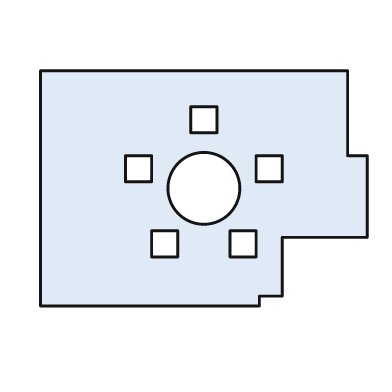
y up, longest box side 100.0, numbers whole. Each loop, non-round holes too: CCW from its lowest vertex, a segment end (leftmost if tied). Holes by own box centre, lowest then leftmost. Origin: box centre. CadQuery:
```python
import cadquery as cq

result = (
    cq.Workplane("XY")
    .moveTo(-50.0, -36.0)
    .lineTo(17.0, -36.0)
    .lineTo(17.0, -33.0)
    .lineTo(24.0, -33.0)
    .lineTo(24.0, -15.0)
    .lineTo(50.0, -15.0)
    .lineTo(50.0, 10.0)
    .lineTo(44.0, 10.0)
    .lineTo(44.0, 36.0)
    .lineTo(-50.0, 36.0)
    .close()
    .moveTo(-16.0, -21.0)
    .lineTo(-8.0, -21.0)
    .lineTo(-8.0, -13.0)
    .lineTo(-16.0, -13.0)
    .close()
    .moveTo(8.0, -21.0)
    .lineTo(16.0, -21.0)
    .lineTo(16.0, -13.0)
    .lineTo(8.0, -13.0)
    .close()
    .moveTo(0.0, 0.0)
    .circle(11.0)
    .moveTo(-24.0, 2.0)
    .lineTo(-16.0, 2.0)
    .lineTo(-16.0, 10.0)
    .lineTo(-24.0, 10.0)
    .close()
    .moveTo(16.0, 2.0)
    .lineTo(24.0, 2.0)
    .lineTo(24.0, 10.0)
    .lineTo(16.0, 10.0)
    .close()
    .moveTo(-4.0, 17.0)
    .lineTo(4.0, 17.0)
    .lineTo(4.0, 25.0)
    .lineTo(-4.0, 25.0)
    .close()
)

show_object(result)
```